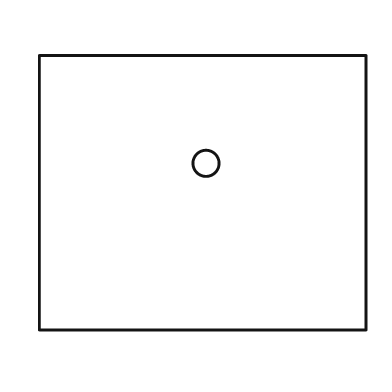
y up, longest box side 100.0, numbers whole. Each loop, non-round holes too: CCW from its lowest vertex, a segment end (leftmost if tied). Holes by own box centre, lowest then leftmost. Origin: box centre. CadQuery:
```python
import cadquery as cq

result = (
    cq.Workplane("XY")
    .moveTo(-50.0, -42.0)
    .lineTo(50.0, -42.0)
    .lineTo(50.0, 42.0)
    .lineTo(-50.0, 42.0)
    .close()
    .moveTo(1.0, 9.0)
    .circle(4.0)
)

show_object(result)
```